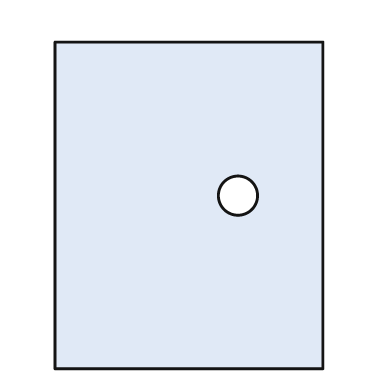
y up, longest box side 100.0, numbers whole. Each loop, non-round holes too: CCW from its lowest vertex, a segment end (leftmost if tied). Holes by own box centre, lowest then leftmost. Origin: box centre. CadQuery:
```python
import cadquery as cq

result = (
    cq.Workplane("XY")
    .moveTo(-41.0, -50.0)
    .lineTo(41.0, -50.0)
    .lineTo(41.0, 50.0)
    .lineTo(-41.0, 50.0)
    .close()
    .moveTo(15.0, 3.0)
    .circle(6.0)
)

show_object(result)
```